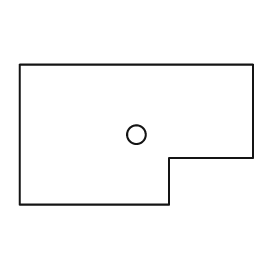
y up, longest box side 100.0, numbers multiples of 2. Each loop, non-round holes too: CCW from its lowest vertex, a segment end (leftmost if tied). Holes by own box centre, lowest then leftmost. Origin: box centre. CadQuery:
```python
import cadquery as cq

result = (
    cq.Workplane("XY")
    .moveTo(-50.0, -30.0)
    .lineTo(14.0, -30.0)
    .lineTo(14.0, -10.0)
    .lineTo(50.0, -10.0)
    .lineTo(50.0, 30.0)
    .lineTo(-50.0, 30.0)
    .close()
    .moveTo(0.0, 0.0)
    .circle(4.0)
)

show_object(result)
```